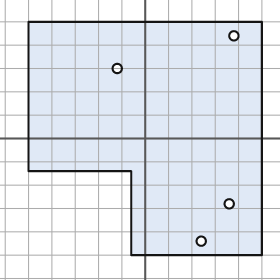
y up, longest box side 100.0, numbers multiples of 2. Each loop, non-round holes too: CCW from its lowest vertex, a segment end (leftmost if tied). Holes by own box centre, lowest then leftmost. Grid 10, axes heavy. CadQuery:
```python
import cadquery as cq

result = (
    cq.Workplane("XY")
    .moveTo(-6.0, -50.0)
    .lineTo(50.0, -50.0)
    .lineTo(50.0, 50.0)
    .lineTo(-50.0, 50.0)
    .lineTo(-50.0, -14.0)
    .lineTo(-6.0, -14.0)
    .close()
    .moveTo(24.0, -44.0)
    .circle(2.0)
    .moveTo(36.0, -28.0)
    .circle(2.0)
    .moveTo(-12.0, 30.0)
    .circle(2.0)
    .moveTo(38.0, 44.0)
    .circle(2.0)
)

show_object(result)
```